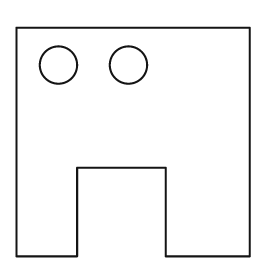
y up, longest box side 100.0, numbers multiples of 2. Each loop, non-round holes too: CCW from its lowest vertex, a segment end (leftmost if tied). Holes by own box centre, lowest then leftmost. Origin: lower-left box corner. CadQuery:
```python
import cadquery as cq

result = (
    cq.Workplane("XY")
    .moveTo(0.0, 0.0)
    .lineTo(26.0, 0.0)
    .lineTo(26.0, 38.0)
    .lineTo(64.0, 38.0)
    .lineTo(64.0, 0.0)
    .lineTo(100.0, 0.0)
    .lineTo(100.0, 98.0)
    .lineTo(0.0, 98.0)
    .close()
    .moveTo(18.0, 82.0)
    .circle(8.0)
    .moveTo(48.0, 82.0)
    .circle(8.0)
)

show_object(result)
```